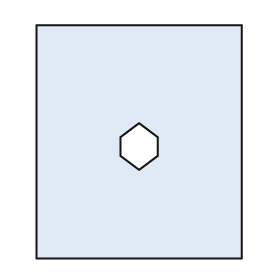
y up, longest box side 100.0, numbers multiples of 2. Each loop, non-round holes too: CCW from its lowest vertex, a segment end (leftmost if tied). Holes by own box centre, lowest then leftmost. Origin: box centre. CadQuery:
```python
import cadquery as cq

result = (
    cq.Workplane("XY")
    .moveTo(-44.0, -50.0)
    .lineTo(44.0, -50.0)
    .lineTo(44.0, 50.0)
    .lineTo(-44.0, 50.0)
    .close()
    .moveTo(0.0, -12.0)
    .lineTo(8.0, -6.0)
    .lineTo(8.0, 2.0)
    .lineTo(0.0, 8.0)
    .lineTo(-8.0, 2.0)
    .lineTo(-8.0, -6.0)
    .close()
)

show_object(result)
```